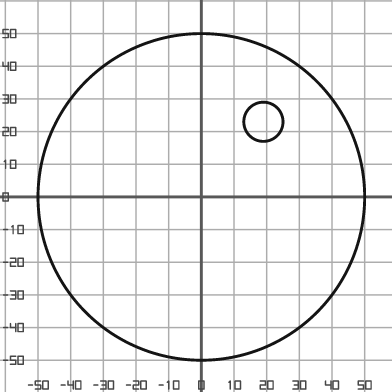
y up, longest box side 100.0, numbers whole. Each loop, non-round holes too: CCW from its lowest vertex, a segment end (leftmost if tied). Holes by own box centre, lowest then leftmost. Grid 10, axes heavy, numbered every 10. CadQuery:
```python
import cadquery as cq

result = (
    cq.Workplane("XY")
    .moveTo(0.0, 0.0)
    .circle(50.0)
    .moveTo(19.0, 23.0)
    .circle(6.0)
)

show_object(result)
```